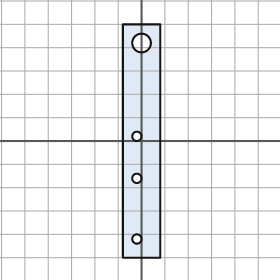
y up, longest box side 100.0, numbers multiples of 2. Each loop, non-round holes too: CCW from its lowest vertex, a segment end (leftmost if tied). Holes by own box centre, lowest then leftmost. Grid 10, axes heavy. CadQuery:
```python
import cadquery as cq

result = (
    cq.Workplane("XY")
    .moveTo(-8.0, -50.0)
    .lineTo(8.0, -50.0)
    .lineTo(8.0, 50.0)
    .lineTo(-8.0, 50.0)
    .close()
    .moveTo(-2.0, -42.0)
    .circle(2.0)
    .moveTo(-2.0, -16.0)
    .circle(2.0)
    .moveTo(-2.0, 2.0)
    .circle(2.0)
    .moveTo(0.0, 42.0)
    .circle(4.0)
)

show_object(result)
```